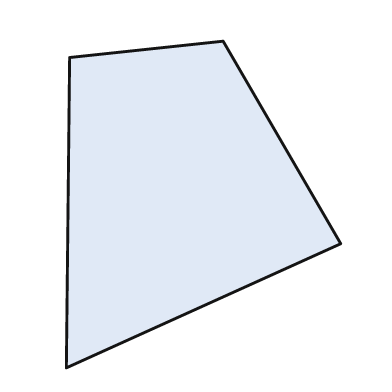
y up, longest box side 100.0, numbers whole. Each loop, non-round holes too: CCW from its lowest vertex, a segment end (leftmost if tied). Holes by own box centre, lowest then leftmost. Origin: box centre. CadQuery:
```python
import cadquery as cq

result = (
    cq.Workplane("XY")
    .moveTo(-42.0, -50.0)
    .lineTo(42.0, -12.0)
    .lineTo(6.0, 50.0)
    .lineTo(-41.0, 45.0)
    .close()
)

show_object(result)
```